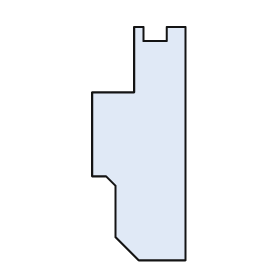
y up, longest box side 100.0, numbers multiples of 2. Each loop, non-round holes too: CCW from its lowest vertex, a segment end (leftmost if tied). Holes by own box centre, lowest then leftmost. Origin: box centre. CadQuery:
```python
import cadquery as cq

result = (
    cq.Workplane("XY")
    .moveTo(0.0, -50.0)
    .lineTo(20.0, -50.0)
    .lineTo(20.0, 50.0)
    .lineTo(12.0, 50.0)
    .lineTo(12.0, 44.0)
    .lineTo(2.0, 44.0)
    .lineTo(2.0, 50.0)
    .lineTo(-2.0, 50.0)
    .lineTo(-2.0, 22.0)
    .lineTo(-20.0, 22.0)
    .lineTo(-20.0, -14.0)
    .lineTo(-14.0, -14.0)
    .lineTo(-10.0, -18.0)
    .lineTo(-10.0, -40.0)
    .close()
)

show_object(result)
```